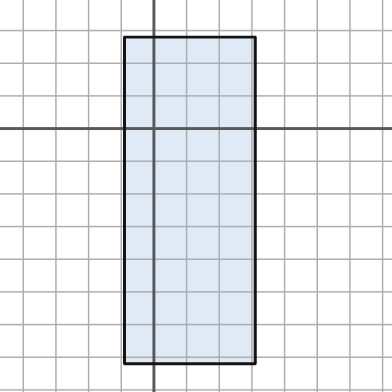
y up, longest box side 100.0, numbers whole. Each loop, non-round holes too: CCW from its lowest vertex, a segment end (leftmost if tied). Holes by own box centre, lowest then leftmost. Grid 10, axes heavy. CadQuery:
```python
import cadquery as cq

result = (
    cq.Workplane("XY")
    .moveTo(-9.0, -72.0)
    .lineTo(31.0, -72.0)
    .lineTo(31.0, 28.0)
    .lineTo(-9.0, 28.0)
    .close()
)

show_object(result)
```